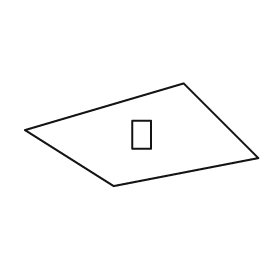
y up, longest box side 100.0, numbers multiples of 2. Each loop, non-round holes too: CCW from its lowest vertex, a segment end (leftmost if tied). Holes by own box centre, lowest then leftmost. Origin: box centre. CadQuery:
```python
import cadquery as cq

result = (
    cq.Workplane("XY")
    .moveTo(-12.0, -22.0)
    .lineTo(50.0, -10.0)
    .lineTo(18.0, 22.0)
    .lineTo(-50.0, 2.0)
    .close()
    .moveTo(-4.0, -6.0)
    .lineTo(4.0, -6.0)
    .lineTo(4.0, 6.0)
    .lineTo(-4.0, 6.0)
    .close()
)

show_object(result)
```